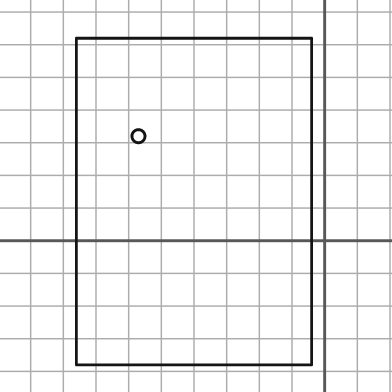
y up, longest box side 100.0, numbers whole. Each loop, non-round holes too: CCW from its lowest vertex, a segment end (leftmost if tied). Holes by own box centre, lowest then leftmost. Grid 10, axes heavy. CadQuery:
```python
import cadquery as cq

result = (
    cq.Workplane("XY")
    .moveTo(-76.0, -38.0)
    .lineTo(-4.0, -38.0)
    .lineTo(-4.0, 62.0)
    .lineTo(-76.0, 62.0)
    .close()
    .moveTo(-57.0, 32.0)
    .circle(2.0)
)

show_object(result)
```